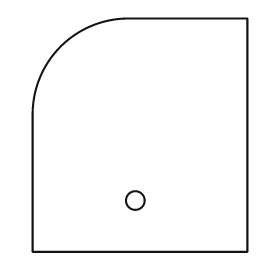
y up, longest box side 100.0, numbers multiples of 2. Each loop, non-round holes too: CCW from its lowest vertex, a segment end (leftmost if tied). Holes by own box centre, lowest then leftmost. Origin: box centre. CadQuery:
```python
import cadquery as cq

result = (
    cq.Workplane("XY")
    .moveTo(-46.0, -50.0)
    .lineTo(46.0, -50.0)
    .lineTo(46.0, 50.0)
    .lineTo(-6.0, 50.0)
    .threePointArc((-34.0, 38.0), (-46.0, 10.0))
    .close()
    .moveTo(-2.0, -28.0)
    .circle(4.0)
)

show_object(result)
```